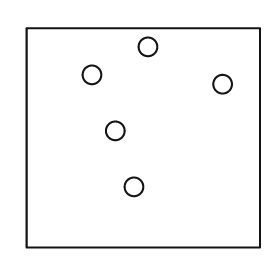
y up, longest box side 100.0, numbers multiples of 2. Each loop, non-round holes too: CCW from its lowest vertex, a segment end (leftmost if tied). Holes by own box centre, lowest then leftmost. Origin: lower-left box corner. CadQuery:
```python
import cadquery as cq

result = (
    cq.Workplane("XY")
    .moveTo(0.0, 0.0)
    .lineTo(100.0, 0.0)
    .lineTo(100.0, 94.0)
    .lineTo(0.0, 94.0)
    .close()
    .moveTo(46.0, 26.0)
    .circle(4.0)
    .moveTo(38.0, 50.0)
    .circle(4.0)
    .moveTo(84.0, 70.0)
    .circle(4.0)
    .moveTo(28.0, 74.0)
    .circle(4.0)
    .moveTo(52.0, 86.0)
    .circle(4.0)
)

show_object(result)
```